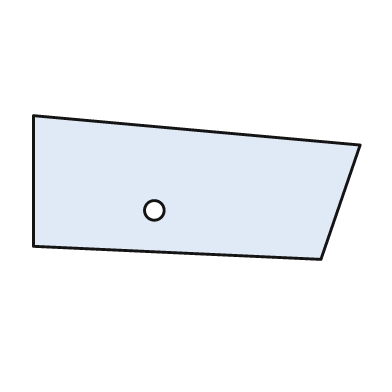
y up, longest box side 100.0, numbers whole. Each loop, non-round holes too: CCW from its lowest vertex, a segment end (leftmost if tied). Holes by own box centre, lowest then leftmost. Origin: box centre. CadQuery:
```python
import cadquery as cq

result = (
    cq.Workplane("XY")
    .moveTo(38.0, -22.0)
    .lineTo(50.0, 13.0)
    .lineTo(-50.0, 22.0)
    .lineTo(-50.0, -18.0)
    .close()
    .moveTo(-13.0, -7.0)
    .circle(3.0)
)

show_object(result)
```